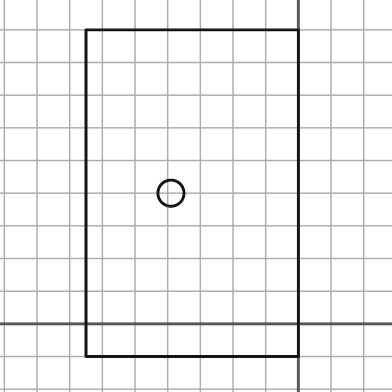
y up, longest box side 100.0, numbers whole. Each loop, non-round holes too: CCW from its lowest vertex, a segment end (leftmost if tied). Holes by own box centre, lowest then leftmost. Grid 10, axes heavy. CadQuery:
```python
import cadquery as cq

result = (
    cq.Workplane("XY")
    .moveTo(-65.0, -10.0)
    .lineTo(0.0, -10.0)
    .lineTo(0.0, 90.0)
    .lineTo(-65.0, 90.0)
    .close()
    .moveTo(-39.0, 40.0)
    .circle(4.0)
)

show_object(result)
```